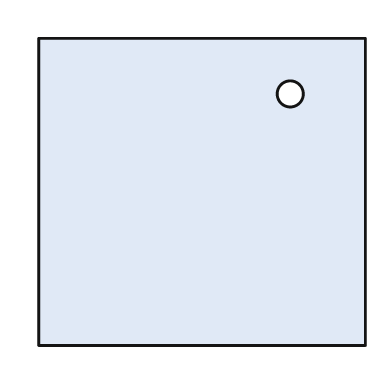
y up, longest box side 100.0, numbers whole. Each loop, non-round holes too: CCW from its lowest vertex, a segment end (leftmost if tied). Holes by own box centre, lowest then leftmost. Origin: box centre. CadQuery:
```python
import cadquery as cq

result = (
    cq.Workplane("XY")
    .moveTo(-50.0, -47.0)
    .lineTo(50.0, -47.0)
    .lineTo(50.0, 47.0)
    .lineTo(-50.0, 47.0)
    .close()
    .moveTo(27.0, 30.0)
    .circle(4.0)
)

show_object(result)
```